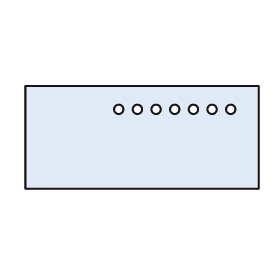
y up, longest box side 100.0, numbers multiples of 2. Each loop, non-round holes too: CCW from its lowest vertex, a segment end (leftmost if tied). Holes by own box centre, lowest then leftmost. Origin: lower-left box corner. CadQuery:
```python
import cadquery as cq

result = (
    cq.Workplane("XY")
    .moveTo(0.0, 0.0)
    .lineTo(100.0, 0.0)
    .lineTo(100.0, 44.0)
    .lineTo(0.0, 44.0)
    .close()
    .moveTo(40.0, 34.0)
    .circle(2.0)
    .moveTo(48.0, 34.0)
    .circle(2.0)
    .moveTo(56.0, 34.0)
    .circle(2.0)
    .moveTo(64.0, 34.0)
    .circle(2.0)
    .moveTo(72.0, 34.0)
    .circle(2.0)
    .moveTo(80.0, 34.0)
    .circle(2.0)
    .moveTo(88.0, 34.0)
    .circle(2.0)
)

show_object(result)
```